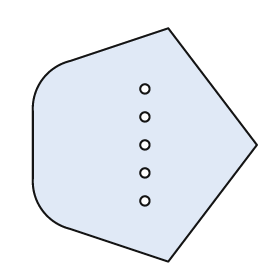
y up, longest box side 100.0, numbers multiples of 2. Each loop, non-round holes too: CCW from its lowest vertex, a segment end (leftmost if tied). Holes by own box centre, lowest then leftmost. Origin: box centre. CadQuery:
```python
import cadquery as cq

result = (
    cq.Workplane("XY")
    .moveTo(10.0, -50.0)
    .lineTo(48.0, 0.0)
    .lineTo(10.0, 50.0)
    .lineTo(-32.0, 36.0)
    .threePointArc((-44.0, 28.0), (-48.0, 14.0))
    .lineTo(-48.0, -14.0)
    .threePointArc((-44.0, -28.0), (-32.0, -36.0))
    .close()
    .moveTo(0.0, -24.0)
    .circle(2.0)
    .moveTo(0.0, -12.0)
    .circle(2.0)
    .moveTo(0.0, 0.0)
    .circle(2.0)
    .moveTo(0.0, 12.0)
    .circle(2.0)
    .moveTo(0.0, 24.0)
    .circle(2.0)
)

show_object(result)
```